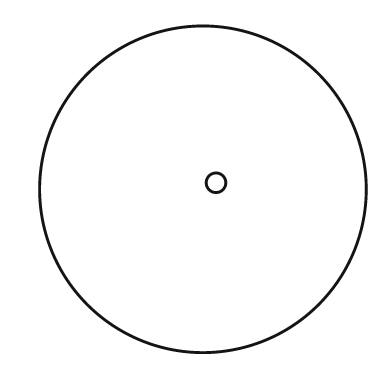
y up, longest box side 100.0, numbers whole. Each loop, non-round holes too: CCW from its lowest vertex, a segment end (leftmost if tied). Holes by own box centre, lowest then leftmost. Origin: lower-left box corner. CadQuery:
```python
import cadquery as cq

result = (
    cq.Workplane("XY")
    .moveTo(50.0, 50.0)
    .circle(50.0)
    .moveTo(54.0, 52.0)
    .circle(3.0)
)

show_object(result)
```